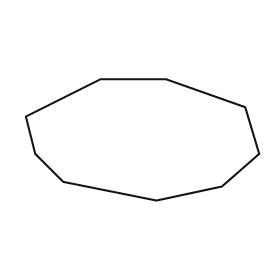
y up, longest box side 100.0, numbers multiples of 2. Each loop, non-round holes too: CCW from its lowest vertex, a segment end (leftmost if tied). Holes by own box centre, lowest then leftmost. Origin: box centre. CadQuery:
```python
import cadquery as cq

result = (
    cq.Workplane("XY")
    .moveTo(6.0, -26.0)
    .lineTo(34.0, -20.0)
    .lineTo(50.0, -6.0)
    .lineTo(44.0, 14.0)
    .lineTo(10.0, 26.0)
    .lineTo(-18.0, 26.0)
    .lineTo(-50.0, 10.0)
    .lineTo(-46.0, -6.0)
    .lineTo(-34.0, -18.0)
    .close()
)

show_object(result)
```